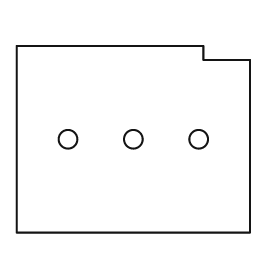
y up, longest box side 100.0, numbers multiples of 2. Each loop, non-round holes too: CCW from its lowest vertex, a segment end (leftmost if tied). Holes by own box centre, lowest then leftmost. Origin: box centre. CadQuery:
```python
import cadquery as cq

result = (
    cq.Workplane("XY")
    .moveTo(-50.0, -40.0)
    .lineTo(50.0, -40.0)
    .lineTo(50.0, 34.0)
    .lineTo(30.0, 34.0)
    .lineTo(30.0, 40.0)
    .lineTo(-50.0, 40.0)
    .close()
    .moveTo(-28.0, 0.0)
    .circle(4.0)
    .moveTo(0.0, 0.0)
    .circle(4.0)
    .moveTo(28.0, 0.0)
    .circle(4.0)
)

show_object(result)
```